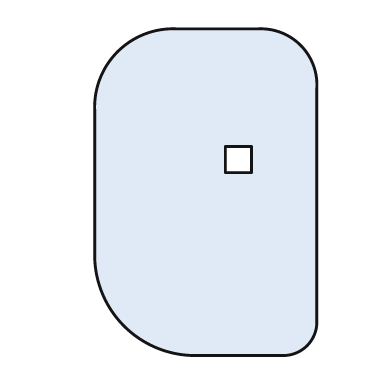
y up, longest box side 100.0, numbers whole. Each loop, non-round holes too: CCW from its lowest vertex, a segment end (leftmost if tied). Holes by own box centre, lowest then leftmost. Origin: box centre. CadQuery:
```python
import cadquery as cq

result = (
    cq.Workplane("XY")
    .moveTo(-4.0, -50.0)
    .lineTo(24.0, -50.0)
    .threePointArc((31.0, -47.0), (34.0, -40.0))
    .lineTo(34.0, 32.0)
    .threePointArc((29.0, 45.0), (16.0, 50.0))
    .lineTo(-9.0, 50.0)
    .threePointArc((-27.0, 43.0), (-34.0, 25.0))
    .lineTo(-34.0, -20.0)
    .threePointArc((-25.0, -41.0), (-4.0, -50.0))
    .close()
    .moveTo(6.0, 6.0)
    .lineTo(14.0, 6.0)
    .lineTo(14.0, 14.0)
    .lineTo(6.0, 14.0)
    .close()
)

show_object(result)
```